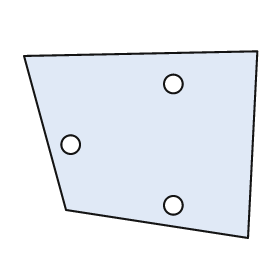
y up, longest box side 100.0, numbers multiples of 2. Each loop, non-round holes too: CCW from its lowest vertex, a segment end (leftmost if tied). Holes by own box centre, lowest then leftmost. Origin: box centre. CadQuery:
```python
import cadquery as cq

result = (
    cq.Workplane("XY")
    .moveTo(46.0, -40.0)
    .lineTo(50.0, 40.0)
    .lineTo(-50.0, 38.0)
    .lineTo(-32.0, -28.0)
    .close()
    .moveTo(14.0, -26.0)
    .circle(4.0)
    .moveTo(-30.0, 0.0)
    .circle(4.0)
    .moveTo(14.0, 26.0)
    .circle(4.0)
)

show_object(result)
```